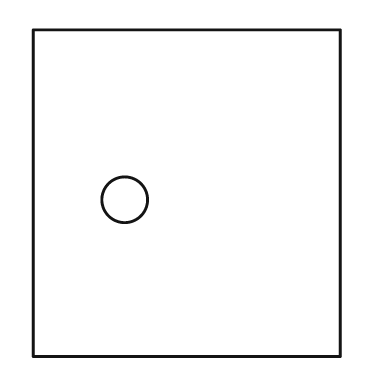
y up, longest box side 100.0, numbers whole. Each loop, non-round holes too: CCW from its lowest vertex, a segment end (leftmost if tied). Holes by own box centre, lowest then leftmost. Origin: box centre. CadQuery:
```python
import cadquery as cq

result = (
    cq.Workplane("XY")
    .moveTo(-47.0, -50.0)
    .lineTo(47.0, -50.0)
    .lineTo(47.0, 50.0)
    .lineTo(-47.0, 50.0)
    .close()
    .moveTo(-19.0, -2.0)
    .circle(7.0)
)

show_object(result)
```